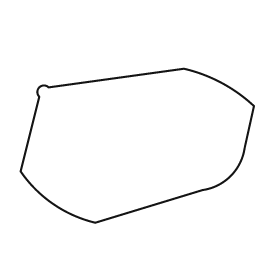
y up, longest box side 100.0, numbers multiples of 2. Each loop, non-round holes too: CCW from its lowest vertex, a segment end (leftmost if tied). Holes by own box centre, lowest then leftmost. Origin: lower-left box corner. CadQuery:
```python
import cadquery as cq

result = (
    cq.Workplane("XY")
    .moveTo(32.0, 0.0)
    .lineTo(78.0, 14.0)
    .threePointArc((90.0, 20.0), (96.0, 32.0))
    .lineTo(100.0, 50.0)
    .threePointArc((86.0, 60.0), (70.0, 66.0))
    .lineTo(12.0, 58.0)
    .threePointArc((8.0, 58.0), (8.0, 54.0))
    .lineTo(0.0, 22.0)
    .threePointArc((14.0, 8.0), (32.0, 0.0))
    .close()
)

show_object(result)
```